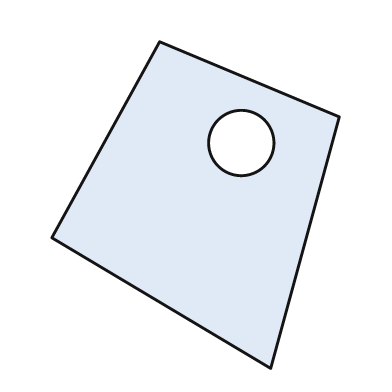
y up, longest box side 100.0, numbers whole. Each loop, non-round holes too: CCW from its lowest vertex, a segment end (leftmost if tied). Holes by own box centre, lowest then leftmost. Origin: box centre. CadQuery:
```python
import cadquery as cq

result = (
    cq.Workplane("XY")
    .moveTo(23.0, -50.0)
    .lineTo(44.0, 27.0)
    .lineTo(-11.0, 50.0)
    .lineTo(-44.0, -10.0)
    .close()
    .moveTo(14.0, 19.0)
    .circle(10.0)
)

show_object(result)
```